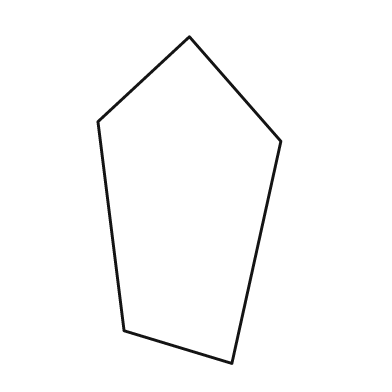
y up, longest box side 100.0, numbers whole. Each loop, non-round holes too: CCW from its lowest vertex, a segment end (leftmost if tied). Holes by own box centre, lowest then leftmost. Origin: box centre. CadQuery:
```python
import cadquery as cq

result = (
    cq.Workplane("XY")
    .moveTo(13.0, -50.0)
    .lineTo(28.0, 18.0)
    .lineTo(0.0, 50.0)
    .lineTo(-28.0, 24.0)
    .lineTo(-20.0, -40.0)
    .close()
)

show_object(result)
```